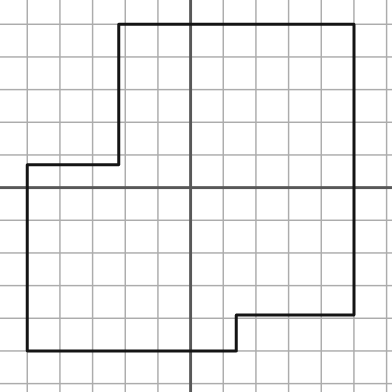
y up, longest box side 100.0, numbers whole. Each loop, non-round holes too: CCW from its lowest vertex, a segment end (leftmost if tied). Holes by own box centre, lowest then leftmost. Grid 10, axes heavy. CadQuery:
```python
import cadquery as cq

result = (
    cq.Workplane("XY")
    .moveTo(-50.0, -50.0)
    .lineTo(14.0, -50.0)
    .lineTo(14.0, -39.0)
    .lineTo(50.0, -39.0)
    .lineTo(50.0, 50.0)
    .lineTo(-22.0, 50.0)
    .lineTo(-22.0, 7.0)
    .lineTo(-50.0, 7.0)
    .close()
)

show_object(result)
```